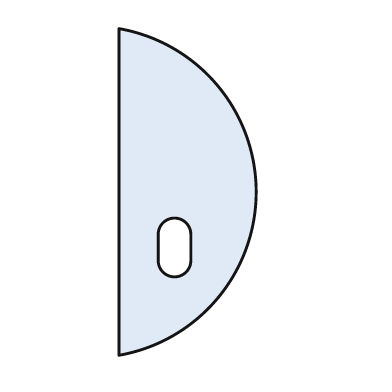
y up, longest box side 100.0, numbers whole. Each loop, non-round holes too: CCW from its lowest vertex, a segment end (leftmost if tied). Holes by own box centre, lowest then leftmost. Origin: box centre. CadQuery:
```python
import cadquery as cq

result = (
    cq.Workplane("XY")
    .moveTo(-21.0, -50.0)
    .threePointArc((21.0, 0.0), (-21.0, 50.0))
    .close()
    .moveTo(-9.0, -21.0)
    .threePointArc((-4.0, -26.0), (1.0, -21.0))
    .lineTo(1.0, -13.0)
    .threePointArc((-4.0, -8.0), (-9.0, -13.0))
    .close()
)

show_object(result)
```